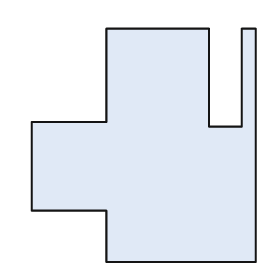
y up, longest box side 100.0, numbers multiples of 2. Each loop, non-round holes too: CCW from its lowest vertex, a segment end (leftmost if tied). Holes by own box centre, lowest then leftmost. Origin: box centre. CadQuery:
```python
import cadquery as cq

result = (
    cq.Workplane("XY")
    .moveTo(-16.0, -50.0)
    .lineTo(48.0, -50.0)
    .lineTo(48.0, 50.0)
    .lineTo(42.0, 50.0)
    .lineTo(42.0, 8.0)
    .lineTo(28.0, 8.0)
    .lineTo(28.0, 50.0)
    .lineTo(-16.0, 50.0)
    .lineTo(-16.0, 10.0)
    .lineTo(-48.0, 10.0)
    .lineTo(-48.0, -28.0)
    .lineTo(-16.0, -28.0)
    .close()
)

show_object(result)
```